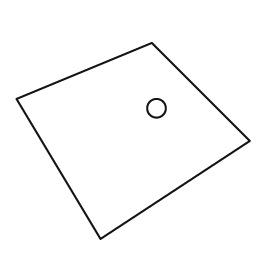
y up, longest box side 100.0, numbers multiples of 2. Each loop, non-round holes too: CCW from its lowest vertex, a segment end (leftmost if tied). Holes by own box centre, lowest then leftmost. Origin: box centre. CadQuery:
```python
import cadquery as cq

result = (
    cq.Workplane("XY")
    .moveTo(-14.0, -42.0)
    .lineTo(50.0, 0.0)
    .lineTo(8.0, 42.0)
    .lineTo(-50.0, 18.0)
    .close()
    .moveTo(10.0, 14.0)
    .circle(4.0)
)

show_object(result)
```